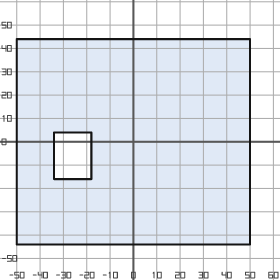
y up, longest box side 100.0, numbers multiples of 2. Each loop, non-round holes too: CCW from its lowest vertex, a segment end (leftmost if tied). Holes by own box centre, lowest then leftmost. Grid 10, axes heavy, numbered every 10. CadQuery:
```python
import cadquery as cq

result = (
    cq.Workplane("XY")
    .moveTo(-50.0, -44.0)
    .lineTo(50.0, -44.0)
    .lineTo(50.0, 44.0)
    .lineTo(-50.0, 44.0)
    .close()
    .moveTo(-34.0, -16.0)
    .lineTo(-18.0, -16.0)
    .lineTo(-18.0, 4.0)
    .lineTo(-34.0, 4.0)
    .close()
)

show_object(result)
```